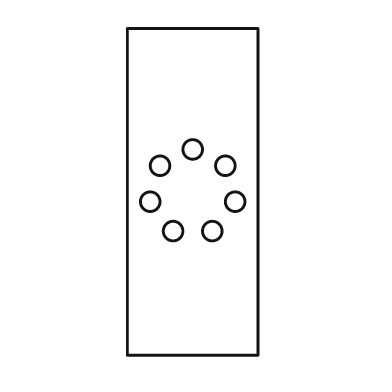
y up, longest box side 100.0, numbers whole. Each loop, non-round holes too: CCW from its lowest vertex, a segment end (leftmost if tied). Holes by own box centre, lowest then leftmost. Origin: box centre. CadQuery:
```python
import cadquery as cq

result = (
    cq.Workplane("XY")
    .moveTo(-20.0, -50.0)
    .lineTo(20.0, -50.0)
    .lineTo(20.0, 50.0)
    .lineTo(-20.0, 50.0)
    .close()
    .moveTo(-6.0, -12.0)
    .circle(3.0)
    .moveTo(6.0, -12.0)
    .circle(3.0)
    .moveTo(-13.0, -3.0)
    .circle(3.0)
    .moveTo(13.0, -3.0)
    .circle(3.0)
    .moveTo(-10.0, 8.0)
    .circle(3.0)
    .moveTo(10.0, 8.0)
    .circle(3.0)
    .moveTo(0.0, 13.0)
    .circle(3.0)
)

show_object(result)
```